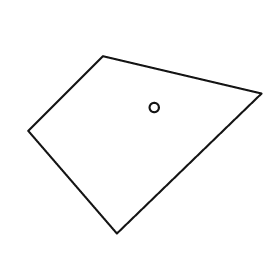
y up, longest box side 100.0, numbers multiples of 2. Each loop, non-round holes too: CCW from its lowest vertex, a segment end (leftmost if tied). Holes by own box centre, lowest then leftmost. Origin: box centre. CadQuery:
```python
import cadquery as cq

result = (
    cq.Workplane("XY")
    .moveTo(-12.0, -38.0)
    .lineTo(50.0, 22.0)
    .lineTo(-18.0, 38.0)
    .lineTo(-50.0, 6.0)
    .close()
    .moveTo(4.0, 16.0)
    .circle(2.0)
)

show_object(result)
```